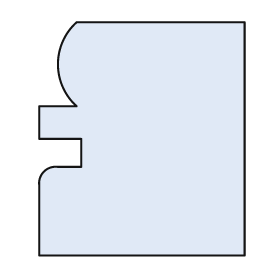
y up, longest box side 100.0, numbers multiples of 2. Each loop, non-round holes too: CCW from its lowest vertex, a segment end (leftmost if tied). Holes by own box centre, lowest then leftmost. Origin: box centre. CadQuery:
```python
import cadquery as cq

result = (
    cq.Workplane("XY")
    .moveTo(-44.0, -50.0)
    .lineTo(44.0, -50.0)
    .lineTo(44.0, 50.0)
    .lineTo(-28.0, 50.0)
    .threePointArc((-36.0, 32.0), (-28.0, 14.0))
    .lineTo(-44.0, 14.0)
    .lineTo(-44.0, 0.0)
    .lineTo(-26.0, 0.0)
    .lineTo(-26.0, -12.0)
    .lineTo(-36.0, -12.0)
    .threePointArc((-42.0, -14.0), (-44.0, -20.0))
    .close()
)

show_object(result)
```